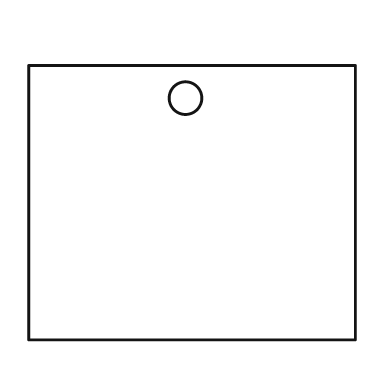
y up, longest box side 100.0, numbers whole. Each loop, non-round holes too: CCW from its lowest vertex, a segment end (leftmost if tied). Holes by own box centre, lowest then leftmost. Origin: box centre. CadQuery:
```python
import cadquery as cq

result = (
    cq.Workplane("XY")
    .moveTo(-50.0, -42.0)
    .lineTo(50.0, -42.0)
    .lineTo(50.0, 42.0)
    .lineTo(-50.0, 42.0)
    .close()
    .moveTo(-2.0, 32.0)
    .circle(5.0)
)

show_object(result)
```